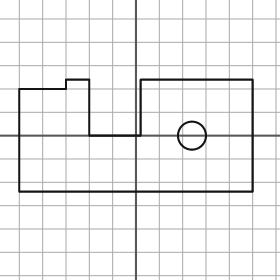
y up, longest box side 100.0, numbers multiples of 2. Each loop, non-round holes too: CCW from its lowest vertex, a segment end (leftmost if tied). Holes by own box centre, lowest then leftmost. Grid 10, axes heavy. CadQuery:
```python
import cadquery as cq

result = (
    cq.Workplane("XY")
    .moveTo(-50.0, -24.0)
    .lineTo(50.0, -24.0)
    .lineTo(50.0, 24.0)
    .lineTo(2.0, 24.0)
    .lineTo(2.0, 0.0)
    .lineTo(-20.0, 0.0)
    .lineTo(-20.0, 24.0)
    .lineTo(-30.0, 24.0)
    .lineTo(-30.0, 20.0)
    .lineTo(-50.0, 20.0)
    .close()
    .moveTo(24.0, 0.0)
    .circle(6.0)
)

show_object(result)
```